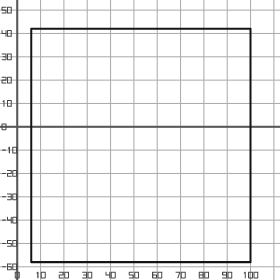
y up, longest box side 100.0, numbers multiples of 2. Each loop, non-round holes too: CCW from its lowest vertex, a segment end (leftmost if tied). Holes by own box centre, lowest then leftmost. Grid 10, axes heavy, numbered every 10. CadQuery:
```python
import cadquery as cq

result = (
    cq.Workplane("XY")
    .moveTo(6.0, -58.0)
    .lineTo(100.0, -58.0)
    .lineTo(100.0, 42.0)
    .lineTo(6.0, 42.0)
    .close()
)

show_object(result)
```